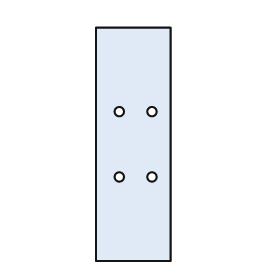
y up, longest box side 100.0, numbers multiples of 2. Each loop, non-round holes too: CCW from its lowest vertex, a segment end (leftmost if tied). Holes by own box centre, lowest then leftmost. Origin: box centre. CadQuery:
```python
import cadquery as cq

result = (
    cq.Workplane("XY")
    .moveTo(-16.0, -50.0)
    .lineTo(16.0, -50.0)
    .lineTo(16.0, 50.0)
    .lineTo(-16.0, 50.0)
    .close()
    .moveTo(-6.0, -14.0)
    .circle(2.0)
    .moveTo(8.0, -14.0)
    .circle(2.0)
    .moveTo(-6.0, 14.0)
    .circle(2.0)
    .moveTo(8.0, 14.0)
    .circle(2.0)
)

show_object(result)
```